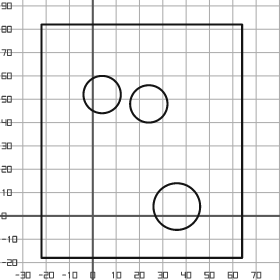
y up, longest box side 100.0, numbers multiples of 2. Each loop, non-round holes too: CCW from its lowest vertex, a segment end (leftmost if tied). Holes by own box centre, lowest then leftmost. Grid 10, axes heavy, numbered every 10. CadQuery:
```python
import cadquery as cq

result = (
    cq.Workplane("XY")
    .moveTo(-22.0, -18.0)
    .lineTo(64.0, -18.0)
    .lineTo(64.0, 82.0)
    .lineTo(-22.0, 82.0)
    .close()
    .moveTo(36.0, 4.0)
    .circle(10.0)
    .moveTo(24.0, 48.0)
    .circle(8.0)
    .moveTo(4.0, 52.0)
    .circle(8.0)
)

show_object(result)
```